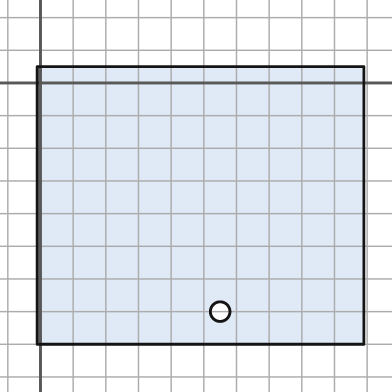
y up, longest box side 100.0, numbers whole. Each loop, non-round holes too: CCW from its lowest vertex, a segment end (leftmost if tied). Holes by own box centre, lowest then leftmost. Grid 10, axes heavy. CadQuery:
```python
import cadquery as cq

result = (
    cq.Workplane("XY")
    .moveTo(-1.0, -80.0)
    .lineTo(99.0, -80.0)
    .lineTo(99.0, 5.0)
    .lineTo(-1.0, 5.0)
    .close()
    .moveTo(55.0, -70.0)
    .circle(3.0)
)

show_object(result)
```